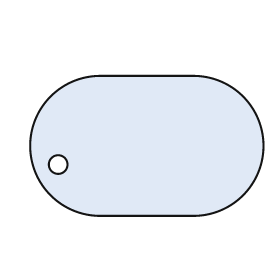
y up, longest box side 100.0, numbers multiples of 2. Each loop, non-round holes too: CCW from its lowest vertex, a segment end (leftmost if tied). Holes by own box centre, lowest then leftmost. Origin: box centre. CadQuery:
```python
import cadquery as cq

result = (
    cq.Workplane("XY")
    .moveTo(-20.0, -30.0)
    .lineTo(20.0, -30.0)
    .threePointArc((50.0, 0.0), (20.0, 30.0))
    .lineTo(-20.0, 30.0)
    .threePointArc((-50.0, 0.0), (-20.0, -30.0))
    .close()
    .moveTo(-38.0, -8.0)
    .circle(4.0)
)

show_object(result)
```